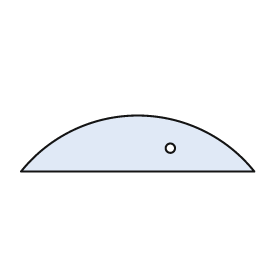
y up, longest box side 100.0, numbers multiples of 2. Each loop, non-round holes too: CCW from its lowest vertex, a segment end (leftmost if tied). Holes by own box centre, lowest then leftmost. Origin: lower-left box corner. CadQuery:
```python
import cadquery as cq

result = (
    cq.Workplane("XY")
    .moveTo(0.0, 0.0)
    .lineTo(100.0, 0.0)
    .threePointArc((50.0, 24.0), (0.0, 0.0))
    .close()
    .moveTo(64.0, 10.0)
    .circle(2.0)
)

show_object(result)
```